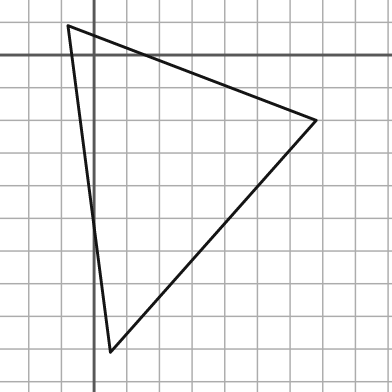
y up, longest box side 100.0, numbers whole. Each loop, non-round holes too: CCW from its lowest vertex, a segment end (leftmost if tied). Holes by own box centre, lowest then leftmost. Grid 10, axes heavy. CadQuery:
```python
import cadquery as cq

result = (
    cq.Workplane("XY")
    .moveTo(5.0, -91.0)
    .lineTo(68.0, -20.0)
    .lineTo(-8.0, 9.0)
    .close()
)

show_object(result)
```